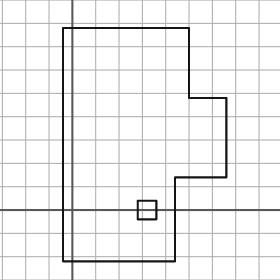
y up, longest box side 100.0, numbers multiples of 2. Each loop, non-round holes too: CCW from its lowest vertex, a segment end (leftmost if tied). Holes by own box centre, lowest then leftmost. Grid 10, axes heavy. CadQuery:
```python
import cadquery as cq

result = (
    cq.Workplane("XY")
    .moveTo(-4.0, -22.0)
    .lineTo(44.0, -22.0)
    .lineTo(44.0, 14.0)
    .lineTo(66.0, 14.0)
    .lineTo(66.0, 48.0)
    .lineTo(50.0, 48.0)
    .lineTo(50.0, 78.0)
    .lineTo(-4.0, 78.0)
    .close()
    .moveTo(28.0, -4.0)
    .lineTo(36.0, -4.0)
    .lineTo(36.0, 4.0)
    .lineTo(28.0, 4.0)
    .close()
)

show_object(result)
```